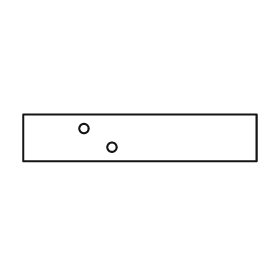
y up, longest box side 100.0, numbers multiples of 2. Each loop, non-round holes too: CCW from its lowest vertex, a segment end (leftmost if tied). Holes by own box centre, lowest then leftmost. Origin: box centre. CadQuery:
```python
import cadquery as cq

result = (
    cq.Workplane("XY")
    .moveTo(-50.0, -10.0)
    .lineTo(50.0, -10.0)
    .lineTo(50.0, 10.0)
    .lineTo(-50.0, 10.0)
    .close()
    .moveTo(-12.0, -4.0)
    .circle(2.0)
    .moveTo(-24.0, 4.0)
    .circle(2.0)
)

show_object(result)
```